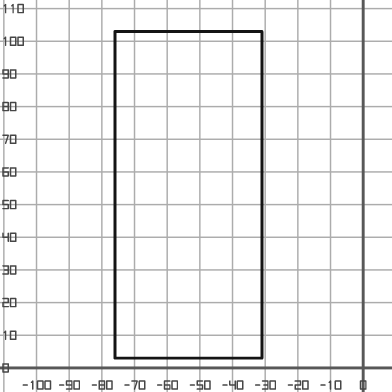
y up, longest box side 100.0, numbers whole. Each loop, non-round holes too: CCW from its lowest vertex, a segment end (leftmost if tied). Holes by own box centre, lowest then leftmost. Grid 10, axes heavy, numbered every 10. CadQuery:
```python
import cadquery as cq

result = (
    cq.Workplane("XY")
    .moveTo(-76.0, 3.0)
    .lineTo(-31.0, 3.0)
    .lineTo(-31.0, 103.0)
    .lineTo(-76.0, 103.0)
    .close()
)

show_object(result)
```